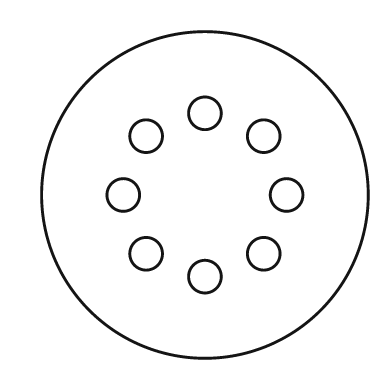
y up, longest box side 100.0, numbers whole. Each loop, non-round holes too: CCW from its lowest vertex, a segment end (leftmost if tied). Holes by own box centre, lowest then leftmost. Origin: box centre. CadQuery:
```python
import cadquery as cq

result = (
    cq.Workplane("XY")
    .moveTo(0.0, 0.0)
    .circle(50.0)
    .moveTo(0.0, -25.0)
    .circle(5.0)
    .moveTo(-18.0, -18.0)
    .circle(5.0)
    .moveTo(18.0, -18.0)
    .circle(5.0)
    .moveTo(-25.0, 0.0)
    .circle(5.0)
    .moveTo(25.0, 0.0)
    .circle(5.0)
    .moveTo(-18.0, 18.0)
    .circle(5.0)
    .moveTo(18.0, 18.0)
    .circle(5.0)
    .moveTo(0.0, 25.0)
    .circle(5.0)
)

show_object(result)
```